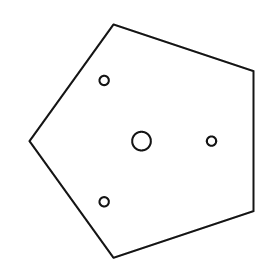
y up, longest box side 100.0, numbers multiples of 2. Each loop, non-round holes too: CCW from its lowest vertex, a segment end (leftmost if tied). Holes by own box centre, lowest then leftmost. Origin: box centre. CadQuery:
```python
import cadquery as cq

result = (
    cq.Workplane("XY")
    .moveTo(-12.0, -50.0)
    .lineTo(48.0, -30.0)
    .lineTo(48.0, 30.0)
    .lineTo(-12.0, 50.0)
    .lineTo(-48.0, 0.0)
    .close()
    .moveTo(-16.0, -26.0)
    .circle(2.0)
    .moveTo(0.0, 0.0)
    .circle(4.0)
    .moveTo(30.0, 0.0)
    .circle(2.0)
    .moveTo(-16.0, 26.0)
    .circle(2.0)
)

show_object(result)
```